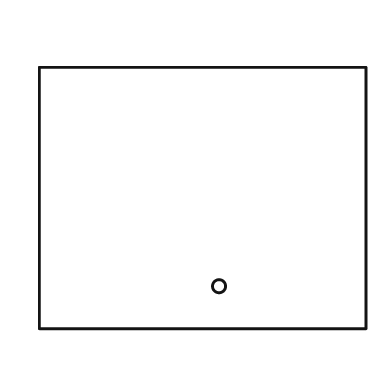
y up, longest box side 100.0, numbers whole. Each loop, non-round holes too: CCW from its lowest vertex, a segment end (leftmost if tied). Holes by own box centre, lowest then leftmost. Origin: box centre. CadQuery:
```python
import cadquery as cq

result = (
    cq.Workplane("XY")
    .moveTo(-50.0, -40.0)
    .lineTo(50.0, -40.0)
    .lineTo(50.0, 40.0)
    .lineTo(-50.0, 40.0)
    .close()
    .moveTo(5.0, -27.0)
    .circle(2.0)
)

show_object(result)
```